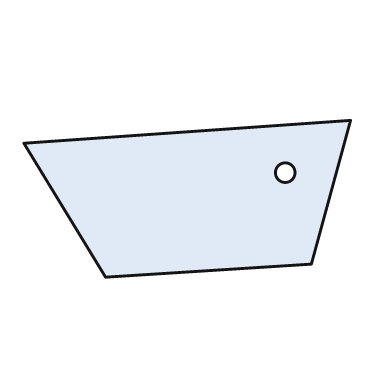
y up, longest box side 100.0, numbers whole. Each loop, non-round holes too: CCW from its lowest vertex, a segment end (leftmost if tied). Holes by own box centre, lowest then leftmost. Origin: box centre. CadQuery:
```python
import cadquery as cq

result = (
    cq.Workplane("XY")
    .moveTo(-25.0, -24.0)
    .lineTo(38.0, -20.0)
    .lineTo(50.0, 24.0)
    .lineTo(-50.0, 17.0)
    .close()
    .moveTo(30.0, 8.0)
    .circle(3.0)
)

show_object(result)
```